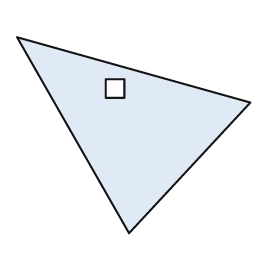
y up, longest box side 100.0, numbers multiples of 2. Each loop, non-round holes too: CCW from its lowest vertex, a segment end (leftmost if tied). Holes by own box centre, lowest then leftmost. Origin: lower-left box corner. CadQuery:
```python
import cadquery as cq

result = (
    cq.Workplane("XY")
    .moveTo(48.0, 0.0)
    .lineTo(100.0, 56.0)
    .lineTo(0.0, 84.0)
    .close()
    .moveTo(38.0, 58.0)
    .lineTo(46.0, 58.0)
    .lineTo(46.0, 66.0)
    .lineTo(38.0, 66.0)
    .close()
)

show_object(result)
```